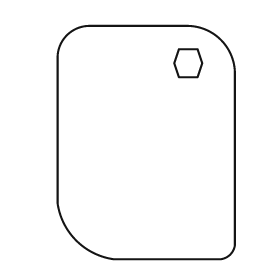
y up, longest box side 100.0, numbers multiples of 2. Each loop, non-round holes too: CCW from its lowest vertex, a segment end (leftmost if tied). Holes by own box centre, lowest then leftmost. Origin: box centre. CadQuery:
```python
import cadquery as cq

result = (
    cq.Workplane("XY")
    .moveTo(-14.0, -50.0)
    .lineTo(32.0, -50.0)
    .threePointArc((36.0, -48.0), (38.0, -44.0))
    .lineTo(38.0, 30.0)
    .threePointArc((32.0, 44.0), (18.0, 50.0))
    .lineTo(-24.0, 50.0)
    .threePointArc((-34.0, 46.0), (-38.0, 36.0))
    .lineTo(-38.0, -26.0)
    .threePointArc((-30.0, -42.0), (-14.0, -50.0))
    .close()
    .moveTo(14.0, 28.0)
    .lineTo(22.0, 28.0)
    .lineTo(24.0, 34.0)
    .lineTo(22.0, 40.0)
    .lineTo(14.0, 40.0)
    .lineTo(12.0, 34.0)
    .close()
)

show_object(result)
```